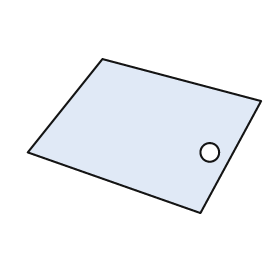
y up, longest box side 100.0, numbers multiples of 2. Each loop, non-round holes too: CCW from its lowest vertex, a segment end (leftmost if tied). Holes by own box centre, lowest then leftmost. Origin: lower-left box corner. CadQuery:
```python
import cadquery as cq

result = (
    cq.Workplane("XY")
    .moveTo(74.0, 0.0)
    .lineTo(100.0, 48.0)
    .lineTo(32.0, 66.0)
    .lineTo(0.0, 26.0)
    .close()
    .moveTo(78.0, 26.0)
    .circle(4.0)
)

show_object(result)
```